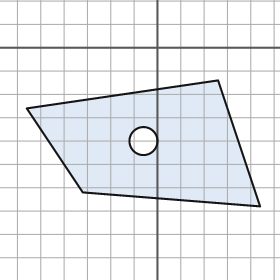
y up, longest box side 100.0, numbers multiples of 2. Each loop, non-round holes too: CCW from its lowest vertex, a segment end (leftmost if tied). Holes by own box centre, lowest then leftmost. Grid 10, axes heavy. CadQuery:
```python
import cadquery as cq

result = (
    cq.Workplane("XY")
    .moveTo(44.0, -68.0)
    .lineTo(26.0, -14.0)
    .lineTo(-56.0, -26.0)
    .lineTo(-32.0, -62.0)
    .close()
    .moveTo(-6.0, -40.0)
    .circle(6.0)
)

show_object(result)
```